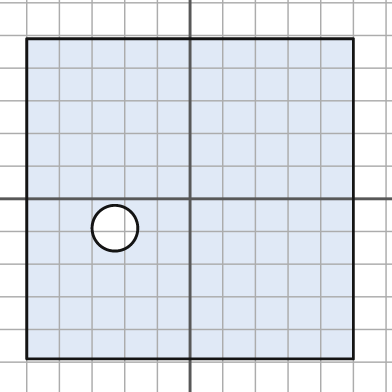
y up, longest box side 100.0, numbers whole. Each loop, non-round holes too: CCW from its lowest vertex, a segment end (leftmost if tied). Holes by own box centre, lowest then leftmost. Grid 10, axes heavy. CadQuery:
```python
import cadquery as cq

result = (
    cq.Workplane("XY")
    .moveTo(-50.0, -49.0)
    .lineTo(50.0, -49.0)
    .lineTo(50.0, 49.0)
    .lineTo(-50.0, 49.0)
    .close()
    .moveTo(-23.0, -9.0)
    .circle(7.0)
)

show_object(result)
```